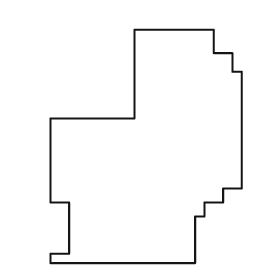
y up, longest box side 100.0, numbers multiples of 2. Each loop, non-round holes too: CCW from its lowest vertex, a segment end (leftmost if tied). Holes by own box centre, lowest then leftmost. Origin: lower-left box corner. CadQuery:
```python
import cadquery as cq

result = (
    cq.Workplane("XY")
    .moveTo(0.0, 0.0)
    .lineTo(62.0, 0.0)
    .lineTo(62.0, 20.0)
    .lineTo(66.0, 20.0)
    .lineTo(66.0, 26.0)
    .lineTo(74.0, 26.0)
    .lineTo(74.0, 32.0)
    .lineTo(82.0, 32.0)
    .lineTo(82.0, 82.0)
    .lineTo(78.0, 82.0)
    .lineTo(78.0, 90.0)
    .lineTo(70.0, 90.0)
    .lineTo(70.0, 100.0)
    .lineTo(36.0, 100.0)
    .lineTo(36.0, 62.0)
    .lineTo(0.0, 62.0)
    .lineTo(0.0, 26.0)
    .lineTo(8.0, 26.0)
    .lineTo(8.0, 4.0)
    .lineTo(0.0, 4.0)
    .close()
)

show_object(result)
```